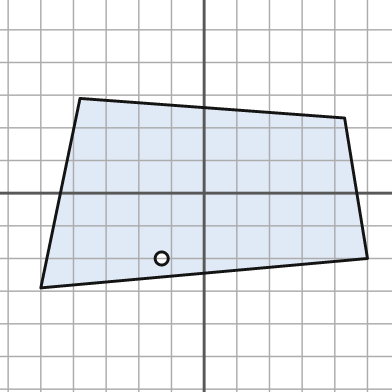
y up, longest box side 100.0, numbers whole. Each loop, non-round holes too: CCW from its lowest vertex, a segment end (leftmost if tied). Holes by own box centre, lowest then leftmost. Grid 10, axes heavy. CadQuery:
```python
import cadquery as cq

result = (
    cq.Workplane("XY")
    .moveTo(-50.0, -29.0)
    .lineTo(50.0, -20.0)
    .lineTo(43.0, 23.0)
    .lineTo(-38.0, 29.0)
    .close()
    .moveTo(-13.0, -20.0)
    .circle(2.0)
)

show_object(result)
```